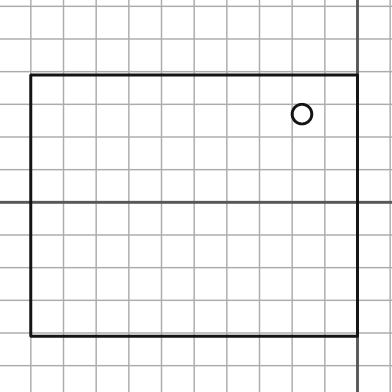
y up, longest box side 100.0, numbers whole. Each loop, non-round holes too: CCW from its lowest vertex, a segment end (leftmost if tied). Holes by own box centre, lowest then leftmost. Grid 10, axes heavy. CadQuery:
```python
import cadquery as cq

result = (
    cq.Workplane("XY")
    .moveTo(-100.0, -41.0)
    .lineTo(0.0, -41.0)
    .lineTo(0.0, 39.0)
    .lineTo(-100.0, 39.0)
    .close()
    .moveTo(-17.0, 27.0)
    .circle(3.0)
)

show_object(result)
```